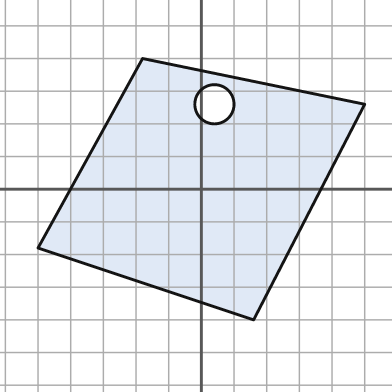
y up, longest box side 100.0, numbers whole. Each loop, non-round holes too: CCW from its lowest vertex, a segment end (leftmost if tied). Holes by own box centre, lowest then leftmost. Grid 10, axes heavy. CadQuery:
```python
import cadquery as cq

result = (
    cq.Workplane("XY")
    .moveTo(16.0, -40.0)
    .lineTo(50.0, 26.0)
    .lineTo(-18.0, 40.0)
    .lineTo(-50.0, -18.0)
    .close()
    .moveTo(4.0, 26.0)
    .circle(6.0)
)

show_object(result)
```